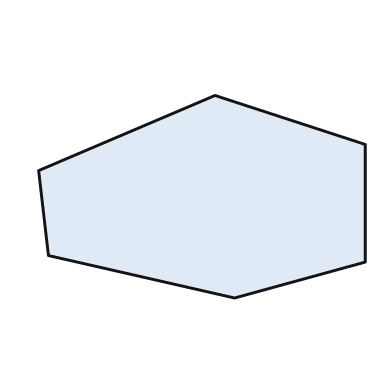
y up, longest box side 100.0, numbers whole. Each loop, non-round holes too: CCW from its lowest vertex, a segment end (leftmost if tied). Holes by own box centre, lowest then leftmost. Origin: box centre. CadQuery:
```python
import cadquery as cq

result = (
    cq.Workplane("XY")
    .moveTo(10.0, -31.0)
    .lineTo(50.0, -20.0)
    .lineTo(50.0, 16.0)
    .lineTo(4.0, 31.0)
    .lineTo(-50.0, 8.0)
    .lineTo(-47.0, -18.0)
    .close()
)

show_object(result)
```